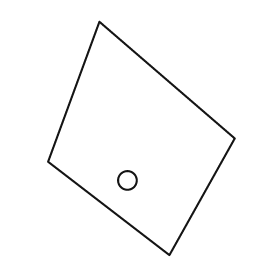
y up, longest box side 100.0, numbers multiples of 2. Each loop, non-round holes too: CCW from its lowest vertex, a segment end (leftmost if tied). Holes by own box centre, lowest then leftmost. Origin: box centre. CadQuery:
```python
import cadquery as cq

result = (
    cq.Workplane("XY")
    .moveTo(12.0, -50.0)
    .lineTo(40.0, 0.0)
    .lineTo(-18.0, 50.0)
    .lineTo(-40.0, -10.0)
    .close()
    .moveTo(-6.0, -18.0)
    .circle(4.0)
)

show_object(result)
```